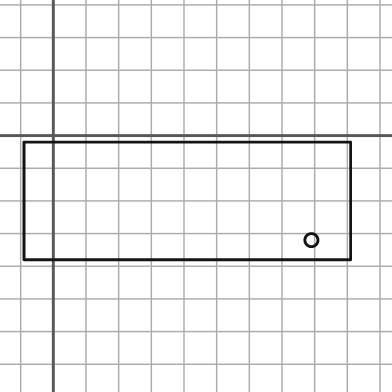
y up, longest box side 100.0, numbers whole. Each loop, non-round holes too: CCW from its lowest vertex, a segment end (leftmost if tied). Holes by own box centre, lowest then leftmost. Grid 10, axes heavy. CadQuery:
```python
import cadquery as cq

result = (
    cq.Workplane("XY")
    .moveTo(-9.0, -38.0)
    .lineTo(91.0, -38.0)
    .lineTo(91.0, -2.0)
    .lineTo(-9.0, -2.0)
    .close()
    .moveTo(79.0, -32.0)
    .circle(2.0)
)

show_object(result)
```